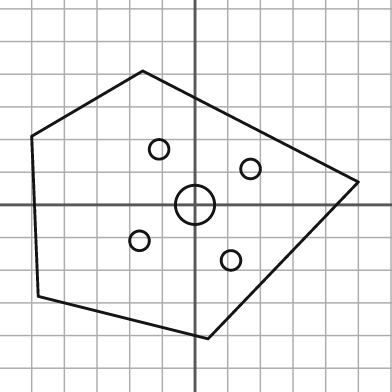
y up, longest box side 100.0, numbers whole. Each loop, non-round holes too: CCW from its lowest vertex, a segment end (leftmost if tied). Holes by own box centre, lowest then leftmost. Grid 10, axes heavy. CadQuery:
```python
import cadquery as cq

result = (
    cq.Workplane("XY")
    .moveTo(4.0, -41.0)
    .lineTo(50.0, 7.0)
    .lineTo(-16.0, 41.0)
    .lineTo(-50.0, 21.0)
    .lineTo(-48.0, -28.0)
    .close()
    .moveTo(11.0, -17.0)
    .circle(3.0)
    .moveTo(-17.0, -11.0)
    .circle(3.0)
    .moveTo(0.0, 0.0)
    .circle(6.0)
    .moveTo(17.0, 11.0)
    .circle(3.0)
    .moveTo(-11.0, 17.0)
    .circle(3.0)
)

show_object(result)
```